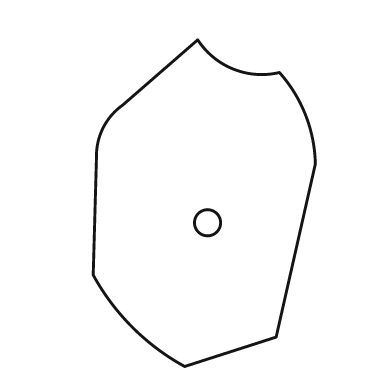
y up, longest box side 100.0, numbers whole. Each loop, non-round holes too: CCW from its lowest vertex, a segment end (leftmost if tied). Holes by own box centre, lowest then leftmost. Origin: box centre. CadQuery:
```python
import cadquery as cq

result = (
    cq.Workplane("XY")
    .moveTo(-6.0, -50.0)
    .lineTo(22.0, -41.0)
    .lineTo(34.0, 12.0)
    .threePointArc((31.0, 27.0), (23.0, 40.0))
    .threePointArc((9.0, 41.0), (-2.0, 50.0))
    .lineTo(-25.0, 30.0)
    .threePointArc((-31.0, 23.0), (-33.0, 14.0))
    .lineTo(-34.0, -22.0)
    .threePointArc((-22.0, -38.0), (-6.0, -50.0))
    .close()
    .moveTo(1.0, -6.0)
    .circle(4.0)
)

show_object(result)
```